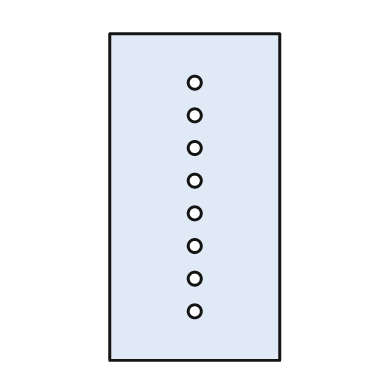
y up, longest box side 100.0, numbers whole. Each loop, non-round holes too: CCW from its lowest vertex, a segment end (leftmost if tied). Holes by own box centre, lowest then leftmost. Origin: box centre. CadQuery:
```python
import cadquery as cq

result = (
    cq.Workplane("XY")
    .moveTo(-26.0, -50.0)
    .lineTo(26.0, -50.0)
    .lineTo(26.0, 50.0)
    .lineTo(-26.0, 50.0)
    .close()
    .moveTo(0.0, -35.0)
    .circle(2.0)
    .moveTo(0.0, -25.0)
    .circle(2.0)
    .moveTo(0.0, -15.0)
    .circle(2.0)
    .moveTo(0.0, -5.0)
    .circle(2.0)
    .moveTo(0.0, 5.0)
    .circle(2.0)
    .moveTo(0.0, 15.0)
    .circle(2.0)
    .moveTo(0.0, 25.0)
    .circle(2.0)
    .moveTo(0.0, 35.0)
    .circle(2.0)
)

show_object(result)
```